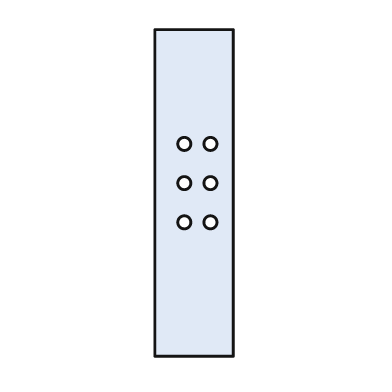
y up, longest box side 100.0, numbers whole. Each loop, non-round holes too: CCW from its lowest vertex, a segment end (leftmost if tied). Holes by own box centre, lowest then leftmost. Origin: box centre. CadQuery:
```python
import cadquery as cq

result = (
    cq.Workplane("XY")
    .moveTo(-12.0, -50.0)
    .lineTo(12.0, -50.0)
    .lineTo(12.0, 50.0)
    .lineTo(-12.0, 50.0)
    .close()
    .moveTo(-3.0, -9.0)
    .circle(2.0)
    .moveTo(5.0, -9.0)
    .circle(2.0)
    .moveTo(-3.0, 3.0)
    .circle(2.0)
    .moveTo(5.0, 3.0)
    .circle(2.0)
    .moveTo(-3.0, 15.0)
    .circle(2.0)
    .moveTo(5.0, 15.0)
    .circle(2.0)
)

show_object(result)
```